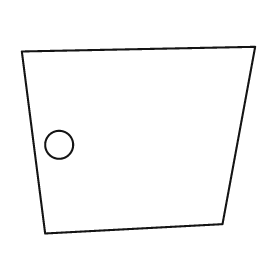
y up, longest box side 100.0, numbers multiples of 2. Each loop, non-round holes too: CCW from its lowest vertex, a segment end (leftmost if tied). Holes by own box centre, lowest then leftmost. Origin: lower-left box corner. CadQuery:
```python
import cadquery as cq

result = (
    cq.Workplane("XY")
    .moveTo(10.0, 0.0)
    .lineTo(86.0, 4.0)
    .lineTo(100.0, 80.0)
    .lineTo(0.0, 78.0)
    .close()
    .moveTo(16.0, 38.0)
    .circle(6.0)
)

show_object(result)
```